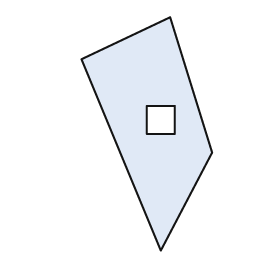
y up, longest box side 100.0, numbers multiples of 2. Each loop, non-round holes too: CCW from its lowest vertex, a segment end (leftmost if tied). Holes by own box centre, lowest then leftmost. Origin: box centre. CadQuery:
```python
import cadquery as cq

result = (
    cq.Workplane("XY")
    .moveTo(6.0, -50.0)
    .lineTo(28.0, -8.0)
    .lineTo(10.0, 50.0)
    .lineTo(-28.0, 32.0)
    .close()
    .moveTo(0.0, 0.0)
    .lineTo(12.0, 0.0)
    .lineTo(12.0, 12.0)
    .lineTo(0.0, 12.0)
    .close()
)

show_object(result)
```